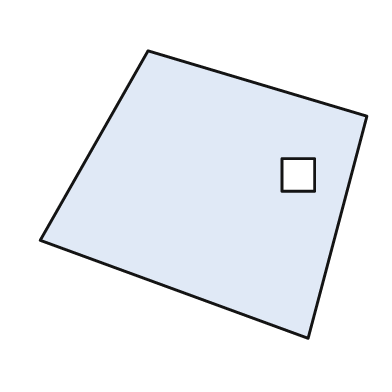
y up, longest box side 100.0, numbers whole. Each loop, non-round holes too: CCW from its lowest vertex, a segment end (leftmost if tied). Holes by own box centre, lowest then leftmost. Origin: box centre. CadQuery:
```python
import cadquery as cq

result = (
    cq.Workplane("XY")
    .moveTo(32.0, -44.0)
    .lineTo(50.0, 24.0)
    .lineTo(-17.0, 44.0)
    .lineTo(-50.0, -14.0)
    .close()
    .moveTo(24.0, 1.0)
    .lineTo(34.0, 1.0)
    .lineTo(34.0, 11.0)
    .lineTo(24.0, 11.0)
    .close()
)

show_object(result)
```